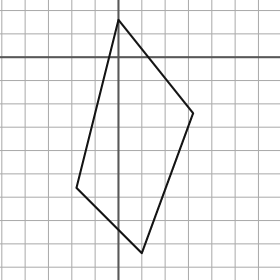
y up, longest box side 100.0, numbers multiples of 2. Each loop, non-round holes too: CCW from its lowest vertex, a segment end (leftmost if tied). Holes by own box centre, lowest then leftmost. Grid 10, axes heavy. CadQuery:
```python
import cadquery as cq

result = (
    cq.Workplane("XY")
    .moveTo(10.0, -84.0)
    .lineTo(32.0, -24.0)
    .lineTo(0.0, 16.0)
    .lineTo(-18.0, -56.0)
    .close()
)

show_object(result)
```